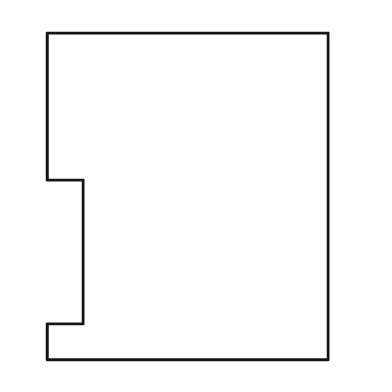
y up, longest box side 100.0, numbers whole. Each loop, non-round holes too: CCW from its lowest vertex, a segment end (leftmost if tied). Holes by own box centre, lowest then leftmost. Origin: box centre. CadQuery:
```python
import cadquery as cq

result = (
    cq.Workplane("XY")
    .moveTo(-43.0, -50.0)
    .lineTo(43.0, -50.0)
    .lineTo(43.0, 50.0)
    .lineTo(-43.0, 50.0)
    .lineTo(-43.0, 5.0)
    .lineTo(-32.0, 5.0)
    .lineTo(-32.0, -39.0)
    .lineTo(-43.0, -39.0)
    .close()
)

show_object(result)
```